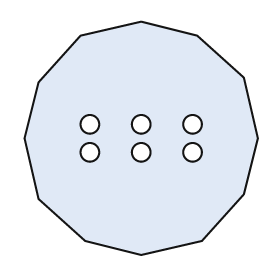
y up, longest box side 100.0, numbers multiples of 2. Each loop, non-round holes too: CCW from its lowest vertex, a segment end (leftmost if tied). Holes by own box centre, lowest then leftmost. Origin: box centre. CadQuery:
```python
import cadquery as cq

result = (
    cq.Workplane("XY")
    .moveTo(0.0, -50.0)
    .lineTo(26.0, -44.0)
    .lineTo(44.0, -24.0)
    .lineTo(50.0, 0.0)
    .lineTo(44.0, 26.0)
    .lineTo(24.0, 44.0)
    .lineTo(0.0, 50.0)
    .lineTo(-26.0, 44.0)
    .lineTo(-44.0, 24.0)
    .lineTo(-50.0, 0.0)
    .lineTo(-44.0, -26.0)
    .lineTo(-24.0, -44.0)
    .close()
    .moveTo(-22.0, -6.0)
    .circle(4.0)
    .moveTo(0.0, -6.0)
    .circle(4.0)
    .moveTo(22.0, -6.0)
    .circle(4.0)
    .moveTo(-22.0, 6.0)
    .circle(4.0)
    .moveTo(0.0, 6.0)
    .circle(4.0)
    .moveTo(22.0, 6.0)
    .circle(4.0)
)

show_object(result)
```